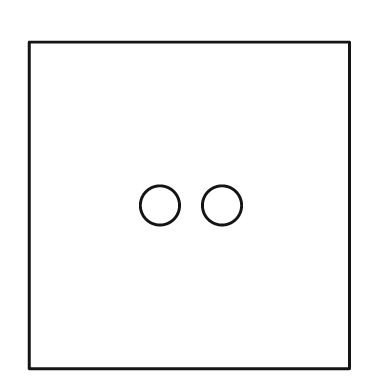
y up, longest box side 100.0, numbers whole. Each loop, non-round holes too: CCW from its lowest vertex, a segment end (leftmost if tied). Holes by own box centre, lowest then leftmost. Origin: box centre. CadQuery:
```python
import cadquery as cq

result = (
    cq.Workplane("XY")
    .moveTo(-49.0, -50.0)
    .lineTo(49.0, -50.0)
    .lineTo(49.0, 50.0)
    .lineTo(-49.0, 50.0)
    .close()
    .moveTo(-9.0, 0.0)
    .circle(6.0)
    .moveTo(10.0, 0.0)
    .circle(6.0)
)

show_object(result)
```